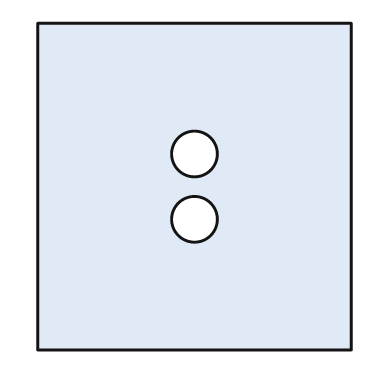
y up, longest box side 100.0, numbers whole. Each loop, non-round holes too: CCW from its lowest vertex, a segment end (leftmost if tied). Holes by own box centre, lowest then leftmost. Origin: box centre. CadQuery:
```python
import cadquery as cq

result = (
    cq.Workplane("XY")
    .moveTo(-48.0, -50.0)
    .lineTo(48.0, -50.0)
    .lineTo(48.0, 50.0)
    .lineTo(-48.0, 50.0)
    .close()
    .moveTo(0.0, -10.0)
    .circle(7.0)
    .moveTo(0.0, 10.0)
    .circle(7.0)
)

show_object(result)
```